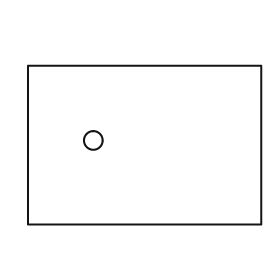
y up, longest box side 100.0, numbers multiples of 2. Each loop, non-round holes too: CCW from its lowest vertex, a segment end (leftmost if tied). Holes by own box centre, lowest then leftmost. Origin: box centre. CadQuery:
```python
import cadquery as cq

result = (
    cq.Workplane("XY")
    .moveTo(-50.0, -34.0)
    .lineTo(50.0, -34.0)
    .lineTo(50.0, 34.0)
    .lineTo(-50.0, 34.0)
    .close()
    .moveTo(-22.0, 2.0)
    .circle(4.0)
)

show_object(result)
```